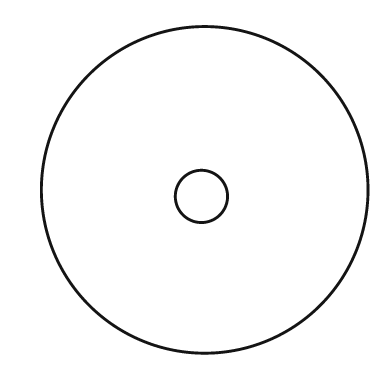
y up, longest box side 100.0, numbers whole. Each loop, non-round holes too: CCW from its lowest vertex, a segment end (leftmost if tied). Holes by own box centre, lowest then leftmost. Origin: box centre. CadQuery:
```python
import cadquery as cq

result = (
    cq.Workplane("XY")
    .moveTo(0.0, 0.0)
    .circle(50.0)
    .moveTo(-1.0, -2.0)
    .circle(8.0)
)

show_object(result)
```